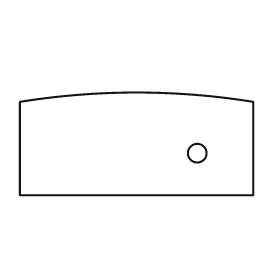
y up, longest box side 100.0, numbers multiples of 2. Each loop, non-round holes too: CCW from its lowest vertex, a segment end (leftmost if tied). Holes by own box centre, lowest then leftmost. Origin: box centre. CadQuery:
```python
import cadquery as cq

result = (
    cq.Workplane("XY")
    .moveTo(-50.0, -22.0)
    .lineTo(50.0, -22.0)
    .lineTo(50.0, 18.0)
    .threePointArc((0.0, 22.0), (-50.0, 18.0))
    .close()
    .moveTo(26.0, -4.0)
    .circle(4.0)
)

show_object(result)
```